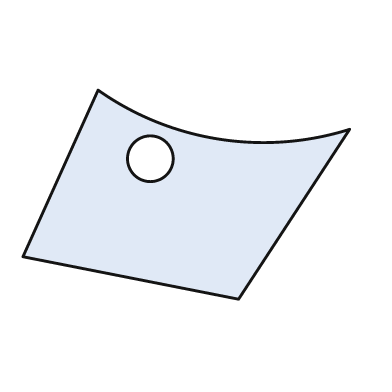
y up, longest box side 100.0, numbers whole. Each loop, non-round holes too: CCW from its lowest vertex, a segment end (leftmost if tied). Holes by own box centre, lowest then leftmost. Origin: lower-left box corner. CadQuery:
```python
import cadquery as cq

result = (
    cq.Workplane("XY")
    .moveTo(66.0, 0.0)
    .lineTo(100.0, 52.0)
    .threePointArc((60.0, 49.0), (23.0, 64.0))
    .lineTo(0.0, 13.0)
    .close()
    .moveTo(39.0, 43.0)
    .circle(7.0)
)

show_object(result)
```